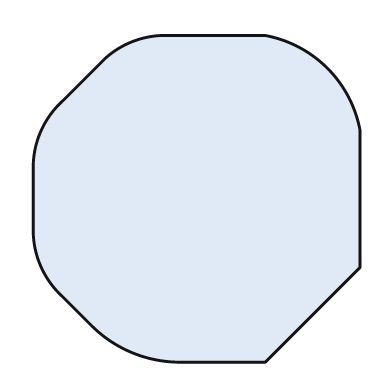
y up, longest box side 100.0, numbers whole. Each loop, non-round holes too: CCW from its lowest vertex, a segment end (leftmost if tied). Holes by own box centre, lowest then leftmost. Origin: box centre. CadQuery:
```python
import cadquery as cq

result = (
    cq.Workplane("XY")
    .moveTo(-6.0, -50.0)
    .lineTo(21.0, -50.0)
    .lineTo(50.0, -21.0)
    .lineTo(50.0, 21.0)
    .threePointArc((40.0, 40.0), (21.0, 50.0))
    .lineTo(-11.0, 50.0)
    .threePointArc((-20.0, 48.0), (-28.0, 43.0))
    .lineTo(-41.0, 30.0)
    .threePointArc((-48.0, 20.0), (-50.0, 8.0))
    .lineTo(-50.0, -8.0)
    .threePointArc((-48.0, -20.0), (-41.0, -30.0))
    .lineTo(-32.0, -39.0)
    .threePointArc((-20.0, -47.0), (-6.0, -50.0))
    .close()
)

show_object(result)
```